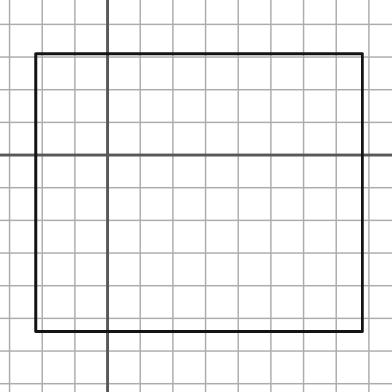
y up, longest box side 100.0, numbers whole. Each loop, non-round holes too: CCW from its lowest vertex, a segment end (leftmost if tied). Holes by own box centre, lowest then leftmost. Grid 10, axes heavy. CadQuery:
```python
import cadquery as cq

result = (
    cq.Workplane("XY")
    .moveTo(-22.0, -54.0)
    .lineTo(78.0, -54.0)
    .lineTo(78.0, 31.0)
    .lineTo(-22.0, 31.0)
    .close()
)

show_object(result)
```